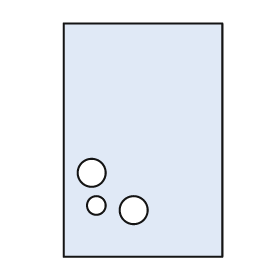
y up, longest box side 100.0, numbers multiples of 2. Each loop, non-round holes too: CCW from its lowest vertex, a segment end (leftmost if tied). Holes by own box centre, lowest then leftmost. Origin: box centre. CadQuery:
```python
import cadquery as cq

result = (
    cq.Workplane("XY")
    .moveTo(-34.0, -50.0)
    .lineTo(34.0, -50.0)
    .lineTo(34.0, 50.0)
    .lineTo(-34.0, 50.0)
    .close()
    .moveTo(-4.0, -30.0)
    .circle(6.0)
    .moveTo(-20.0, -28.0)
    .circle(4.0)
    .moveTo(-22.0, -14.0)
    .circle(6.0)
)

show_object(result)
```